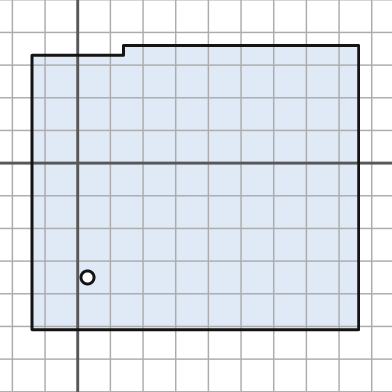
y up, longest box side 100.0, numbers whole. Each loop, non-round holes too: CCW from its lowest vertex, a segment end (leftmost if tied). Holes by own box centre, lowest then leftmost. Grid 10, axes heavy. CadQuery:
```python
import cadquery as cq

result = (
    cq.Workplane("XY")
    .moveTo(-14.0, -51.0)
    .lineTo(86.0, -51.0)
    .lineTo(86.0, 36.0)
    .lineTo(14.0, 36.0)
    .lineTo(14.0, 33.0)
    .lineTo(-14.0, 33.0)
    .close()
    .moveTo(3.0, -35.0)
    .circle(2.0)
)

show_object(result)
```